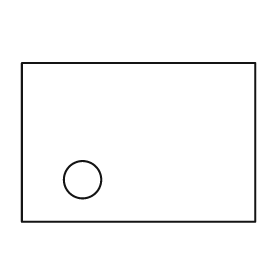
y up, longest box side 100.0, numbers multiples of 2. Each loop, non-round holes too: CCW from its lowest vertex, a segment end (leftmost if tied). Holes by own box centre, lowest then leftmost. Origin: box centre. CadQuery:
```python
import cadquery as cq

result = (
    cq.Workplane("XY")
    .moveTo(-50.0, -34.0)
    .lineTo(50.0, -34.0)
    .lineTo(50.0, 34.0)
    .lineTo(-50.0, 34.0)
    .close()
    .moveTo(-24.0, -16.0)
    .circle(8.0)
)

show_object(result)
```